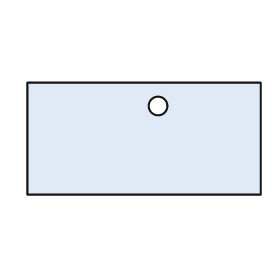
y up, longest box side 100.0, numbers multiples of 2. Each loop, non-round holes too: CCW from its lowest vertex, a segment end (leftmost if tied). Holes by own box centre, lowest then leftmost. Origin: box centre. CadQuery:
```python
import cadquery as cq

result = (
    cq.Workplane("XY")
    .moveTo(-50.0, -24.0)
    .lineTo(50.0, -24.0)
    .lineTo(50.0, 24.0)
    .lineTo(-50.0, 24.0)
    .close()
    .moveTo(6.0, 14.0)
    .circle(4.0)
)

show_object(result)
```